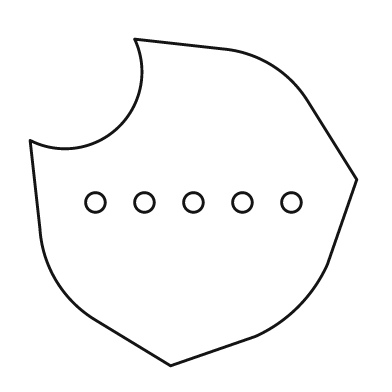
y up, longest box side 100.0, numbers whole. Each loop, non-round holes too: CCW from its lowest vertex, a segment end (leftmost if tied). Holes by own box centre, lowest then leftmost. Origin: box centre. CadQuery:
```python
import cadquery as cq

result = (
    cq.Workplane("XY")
    .moveTo(-7.0, -50.0)
    .lineTo(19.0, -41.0)
    .threePointArc((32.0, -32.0), (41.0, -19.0))
    .lineTo(50.0, 7.0)
    .lineTo(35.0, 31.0)
    .threePointArc((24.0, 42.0), (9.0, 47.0))
    .lineTo(-18.0, 50.0)
    .threePointArc((-23.0, 23.0), (-50.0, 19.0))
    .lineTo(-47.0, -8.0)
    .threePointArc((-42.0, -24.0), (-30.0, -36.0))
    .close()
    .moveTo(-30.0, 0.0)
    .circle(3.0)
    .moveTo(-15.0, 0.0)
    .circle(3.0)
    .moveTo(0.0, 0.0)
    .circle(3.0)
    .moveTo(15.0, 0.0)
    .circle(3.0)
    .moveTo(30.0, 0.0)
    .circle(3.0)
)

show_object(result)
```